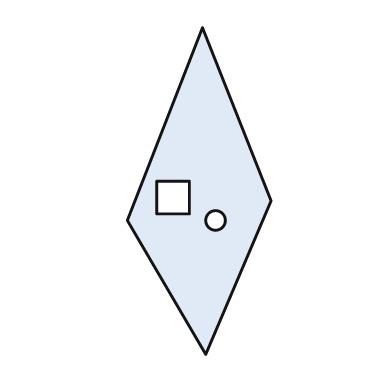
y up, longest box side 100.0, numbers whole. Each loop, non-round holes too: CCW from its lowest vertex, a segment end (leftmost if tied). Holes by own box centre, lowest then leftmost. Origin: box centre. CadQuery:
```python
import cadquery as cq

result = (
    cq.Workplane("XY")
    .moveTo(2.0, -50.0)
    .lineTo(22.0, -3.0)
    .lineTo(1.0, 50.0)
    .lineTo(-22.0, -9.0)
    .close()
    .moveTo(5.0, -9.0)
    .circle(3.0)
    .moveTo(-13.0, -7.0)
    .lineTo(-3.0, -7.0)
    .lineTo(-3.0, 3.0)
    .lineTo(-13.0, 3.0)
    .close()
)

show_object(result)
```